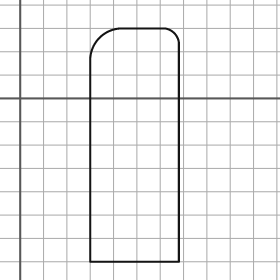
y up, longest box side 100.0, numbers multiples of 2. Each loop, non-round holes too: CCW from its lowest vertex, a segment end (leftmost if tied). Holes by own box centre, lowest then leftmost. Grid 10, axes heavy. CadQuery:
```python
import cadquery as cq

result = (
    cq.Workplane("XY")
    .moveTo(30.0, -70.0)
    .lineTo(68.0, -70.0)
    .lineTo(68.0, 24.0)
    .threePointArc((66.0, 28.0), (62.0, 30.0))
    .lineTo(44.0, 30.0)
    .threePointArc((34.0, 26.0), (30.0, 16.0))
    .close()
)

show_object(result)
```